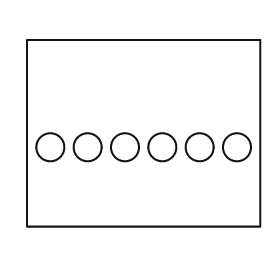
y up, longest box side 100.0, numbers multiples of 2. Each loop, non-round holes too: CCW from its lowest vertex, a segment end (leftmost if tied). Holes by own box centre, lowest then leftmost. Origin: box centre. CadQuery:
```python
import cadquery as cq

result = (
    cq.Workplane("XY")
    .moveTo(-50.0, -40.0)
    .lineTo(50.0, -40.0)
    .lineTo(50.0, 40.0)
    .lineTo(-50.0, 40.0)
    .close()
    .moveTo(-40.0, -6.0)
    .circle(6.0)
    .moveTo(-24.0, -6.0)
    .circle(6.0)
    .moveTo(-8.0, -6.0)
    .circle(6.0)
    .moveTo(8.0, -6.0)
    .circle(6.0)
    .moveTo(24.0, -6.0)
    .circle(6.0)
    .moveTo(40.0, -6.0)
    .circle(6.0)
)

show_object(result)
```